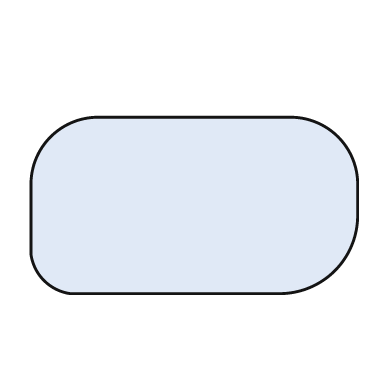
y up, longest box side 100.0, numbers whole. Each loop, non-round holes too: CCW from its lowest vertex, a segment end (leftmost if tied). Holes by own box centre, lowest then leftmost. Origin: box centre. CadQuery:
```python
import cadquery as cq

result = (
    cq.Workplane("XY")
    .moveTo(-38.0, -27.0)
    .lineTo(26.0, -27.0)
    .threePointArc((43.0, -20.0), (50.0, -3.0))
    .lineTo(50.0, 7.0)
    .threePointArc((44.0, 21.0), (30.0, 27.0))
    .lineTo(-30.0, 27.0)
    .threePointArc((-44.0, 21.0), (-50.0, 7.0))
    .lineTo(-50.0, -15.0)
    .threePointArc((-46.0, -23.0), (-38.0, -27.0))
    .close()
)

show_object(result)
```